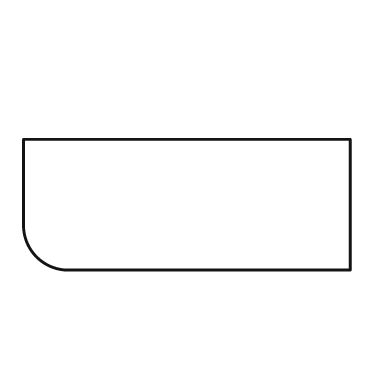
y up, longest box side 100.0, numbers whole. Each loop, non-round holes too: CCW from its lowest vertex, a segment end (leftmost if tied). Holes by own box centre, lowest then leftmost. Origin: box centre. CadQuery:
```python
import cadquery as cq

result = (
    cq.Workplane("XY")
    .moveTo(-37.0, -20.0)
    .lineTo(50.0, -20.0)
    .lineTo(50.0, 20.0)
    .lineTo(-50.0, 20.0)
    .lineTo(-50.0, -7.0)
    .threePointArc((-46.0, -16.0), (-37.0, -20.0))
    .close()
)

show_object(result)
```